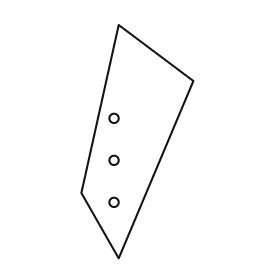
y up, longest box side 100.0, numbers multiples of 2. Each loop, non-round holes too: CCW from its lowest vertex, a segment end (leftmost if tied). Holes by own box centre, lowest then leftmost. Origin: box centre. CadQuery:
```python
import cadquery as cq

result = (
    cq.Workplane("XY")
    .moveTo(-8.0, -50.0)
    .lineTo(24.0, 26.0)
    .lineTo(-8.0, 50.0)
    .lineTo(-24.0, -22.0)
    .close()
    .moveTo(-10.0, -26.0)
    .circle(2.0)
    .moveTo(-10.0, -8.0)
    .circle(2.0)
    .moveTo(-10.0, 10.0)
    .circle(2.0)
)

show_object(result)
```